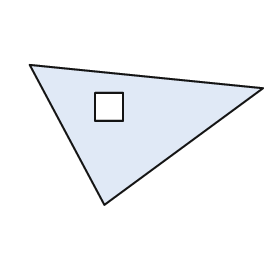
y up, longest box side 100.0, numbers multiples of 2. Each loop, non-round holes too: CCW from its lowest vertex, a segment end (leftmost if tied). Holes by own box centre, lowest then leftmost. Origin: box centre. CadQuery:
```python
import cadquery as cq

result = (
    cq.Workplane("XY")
    .moveTo(-18.0, -30.0)
    .lineTo(50.0, 20.0)
    .lineTo(-50.0, 30.0)
    .close()
    .moveTo(-22.0, 6.0)
    .lineTo(-10.0, 6.0)
    .lineTo(-10.0, 18.0)
    .lineTo(-22.0, 18.0)
    .close()
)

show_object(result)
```